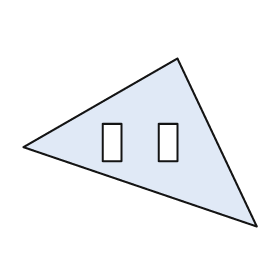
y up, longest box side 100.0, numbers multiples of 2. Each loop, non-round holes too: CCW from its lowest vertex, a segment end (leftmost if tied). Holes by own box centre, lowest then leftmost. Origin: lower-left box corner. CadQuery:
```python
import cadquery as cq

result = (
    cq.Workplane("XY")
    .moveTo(100.0, 0.0)
    .lineTo(66.0, 72.0)
    .lineTo(0.0, 34.0)
    .close()
    .moveTo(34.0, 28.0)
    .lineTo(42.0, 28.0)
    .lineTo(42.0, 44.0)
    .lineTo(34.0, 44.0)
    .close()
    .moveTo(58.0, 28.0)
    .lineTo(66.0, 28.0)
    .lineTo(66.0, 44.0)
    .lineTo(58.0, 44.0)
    .close()
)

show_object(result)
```